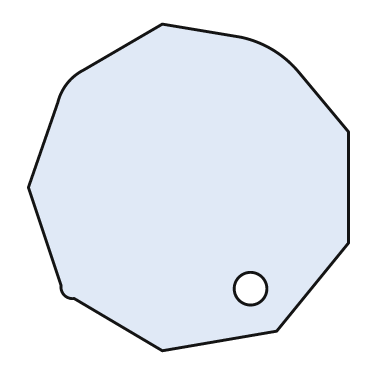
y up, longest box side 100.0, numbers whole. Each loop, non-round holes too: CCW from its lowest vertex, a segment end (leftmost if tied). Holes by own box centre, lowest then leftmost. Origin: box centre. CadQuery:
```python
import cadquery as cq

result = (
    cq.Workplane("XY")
    .moveTo(-8.0, -50.0)
    .lineTo(27.0, -44.0)
    .lineTo(49.0, -17.0)
    .lineTo(49.0, 17.0)
    .lineTo(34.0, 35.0)
    .threePointArc((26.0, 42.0), (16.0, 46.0))
    .lineTo(-8.0, 50.0)
    .lineTo(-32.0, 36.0)
    .threePointArc((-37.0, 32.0), (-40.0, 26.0))
    .lineTo(-49.0, 0.0)
    .lineTo(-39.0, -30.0)
    .threePointArc((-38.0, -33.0), (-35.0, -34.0))
    .close()
    .moveTo(19.0, -31.0)
    .circle(5.0)
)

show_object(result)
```